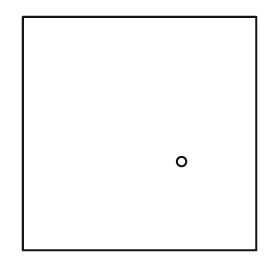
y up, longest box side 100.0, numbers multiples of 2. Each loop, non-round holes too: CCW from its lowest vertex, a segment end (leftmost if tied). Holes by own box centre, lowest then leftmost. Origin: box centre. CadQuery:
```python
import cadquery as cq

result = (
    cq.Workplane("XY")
    .moveTo(-50.0, -50.0)
    .lineTo(50.0, -50.0)
    .lineTo(50.0, 50.0)
    .lineTo(-50.0, 50.0)
    .close()
    .moveTo(18.0, -12.0)
    .circle(2.0)
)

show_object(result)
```